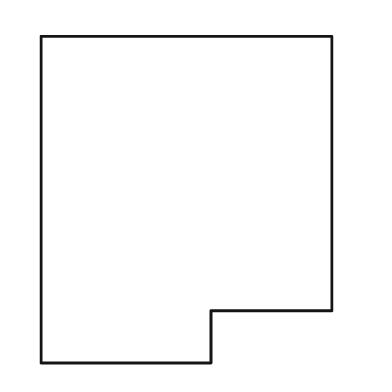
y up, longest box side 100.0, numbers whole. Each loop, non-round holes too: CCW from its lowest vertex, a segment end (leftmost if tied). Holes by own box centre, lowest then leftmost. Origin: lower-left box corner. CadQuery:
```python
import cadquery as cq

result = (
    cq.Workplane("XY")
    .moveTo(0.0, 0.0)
    .lineTo(52.0, 0.0)
    .lineTo(52.0, 16.0)
    .lineTo(89.0, 16.0)
    .lineTo(89.0, 100.0)
    .lineTo(0.0, 100.0)
    .close()
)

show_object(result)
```